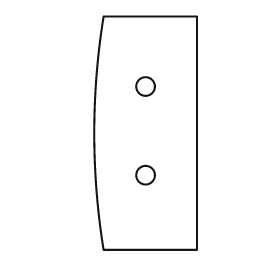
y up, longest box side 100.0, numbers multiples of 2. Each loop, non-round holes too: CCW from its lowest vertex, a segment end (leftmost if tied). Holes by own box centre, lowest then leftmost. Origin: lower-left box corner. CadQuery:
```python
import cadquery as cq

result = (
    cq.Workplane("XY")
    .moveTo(4.0, 0.0)
    .lineTo(44.0, 0.0)
    .lineTo(44.0, 100.0)
    .lineTo(4.0, 100.0)
    .threePointArc((0.0, 50.0), (4.0, 0.0))
    .close()
    .moveTo(22.0, 32.0)
    .circle(4.0)
    .moveTo(22.0, 70.0)
    .circle(4.0)
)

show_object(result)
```